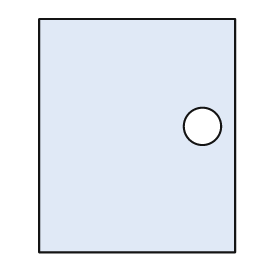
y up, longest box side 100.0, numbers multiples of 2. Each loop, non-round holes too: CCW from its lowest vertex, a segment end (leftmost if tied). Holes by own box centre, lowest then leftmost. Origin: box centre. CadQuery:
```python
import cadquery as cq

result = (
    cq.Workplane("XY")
    .moveTo(-42.0, -50.0)
    .lineTo(42.0, -50.0)
    .lineTo(42.0, 50.0)
    .lineTo(-42.0, 50.0)
    .close()
    .moveTo(28.0, 4.0)
    .circle(8.0)
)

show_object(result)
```